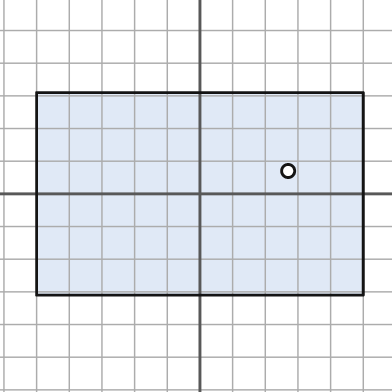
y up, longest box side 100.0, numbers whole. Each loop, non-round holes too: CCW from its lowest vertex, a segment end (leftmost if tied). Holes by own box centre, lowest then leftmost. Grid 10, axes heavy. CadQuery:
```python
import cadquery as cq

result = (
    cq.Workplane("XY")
    .moveTo(-50.0, -31.0)
    .lineTo(50.0, -31.0)
    .lineTo(50.0, 31.0)
    .lineTo(-50.0, 31.0)
    .close()
    .moveTo(27.0, 7.0)
    .circle(2.0)
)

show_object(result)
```